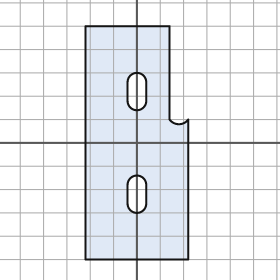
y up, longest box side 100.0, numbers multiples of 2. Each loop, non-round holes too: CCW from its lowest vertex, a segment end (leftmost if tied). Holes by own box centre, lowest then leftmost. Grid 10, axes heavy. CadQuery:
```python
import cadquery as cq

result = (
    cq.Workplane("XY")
    .moveTo(-22.0, -50.0)
    .lineTo(22.0, -50.0)
    .lineTo(22.0, 10.0)
    .threePointArc((18.0, 8.0), (14.0, 10.0))
    .lineTo(14.0, 50.0)
    .lineTo(-22.0, 50.0)
    .close()
    .moveTo(-4.0, -26.0)
    .threePointArc((0.0, -30.0), (4.0, -26.0))
    .lineTo(4.0, -18.0)
    .threePointArc((0.0, -14.0), (-4.0, -18.0))
    .close()
    .moveTo(-4.0, 18.0)
    .threePointArc((0.0, 14.0), (4.0, 18.0))
    .lineTo(4.0, 26.0)
    .threePointArc((0.0, 30.0), (-4.0, 26.0))
    .close()
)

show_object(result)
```